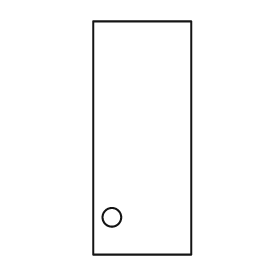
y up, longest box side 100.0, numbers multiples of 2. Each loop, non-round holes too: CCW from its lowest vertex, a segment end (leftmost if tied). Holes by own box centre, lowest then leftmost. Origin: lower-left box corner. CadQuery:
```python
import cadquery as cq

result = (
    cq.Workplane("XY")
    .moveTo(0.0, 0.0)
    .lineTo(42.0, 0.0)
    .lineTo(42.0, 100.0)
    .lineTo(0.0, 100.0)
    .close()
    .moveTo(8.0, 16.0)
    .circle(4.0)
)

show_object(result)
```